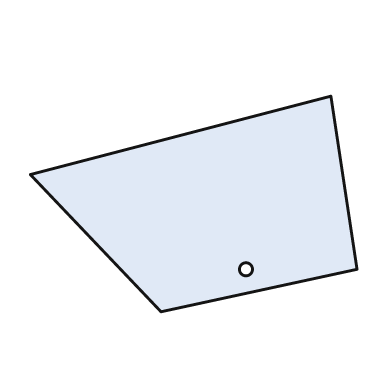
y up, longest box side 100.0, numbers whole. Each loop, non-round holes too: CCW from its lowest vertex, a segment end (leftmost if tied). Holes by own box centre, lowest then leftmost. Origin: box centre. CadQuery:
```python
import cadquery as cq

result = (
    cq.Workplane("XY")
    .moveTo(-10.0, -33.0)
    .lineTo(50.0, -20.0)
    .lineTo(42.0, 33.0)
    .lineTo(-50.0, 9.0)
    .close()
    .moveTo(16.0, -20.0)
    .circle(2.0)
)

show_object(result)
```